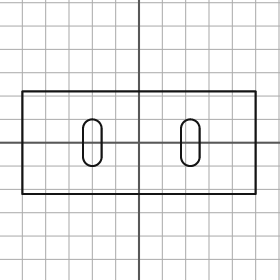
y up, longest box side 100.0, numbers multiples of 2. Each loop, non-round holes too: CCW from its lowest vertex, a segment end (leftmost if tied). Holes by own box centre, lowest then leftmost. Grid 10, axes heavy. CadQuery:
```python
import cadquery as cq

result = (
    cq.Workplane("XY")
    .moveTo(-50.0, -22.0)
    .lineTo(50.0, -22.0)
    .lineTo(50.0, 22.0)
    .lineTo(-50.0, 22.0)
    .close()
    .moveTo(-24.0, -6.0)
    .threePointArc((-20.0, -10.0), (-16.0, -6.0))
    .lineTo(-16.0, 6.0)
    .threePointArc((-20.0, 10.0), (-24.0, 6.0))
    .close()
    .moveTo(18.0, -6.0)
    .threePointArc((22.0, -10.0), (26.0, -6.0))
    .lineTo(26.0, 6.0)
    .threePointArc((22.0, 10.0), (18.0, 6.0))
    .close()
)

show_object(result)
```